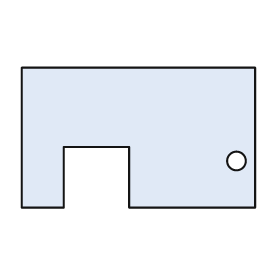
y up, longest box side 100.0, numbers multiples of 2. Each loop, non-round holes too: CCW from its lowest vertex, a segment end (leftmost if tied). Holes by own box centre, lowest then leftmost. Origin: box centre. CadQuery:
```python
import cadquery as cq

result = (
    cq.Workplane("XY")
    .moveTo(-50.0, -30.0)
    .lineTo(-32.0, -30.0)
    .lineTo(-32.0, -4.0)
    .lineTo(-4.0, -4.0)
    .lineTo(-4.0, -30.0)
    .lineTo(50.0, -30.0)
    .lineTo(50.0, 30.0)
    .lineTo(-50.0, 30.0)
    .close()
    .moveTo(42.0, -10.0)
    .circle(4.0)
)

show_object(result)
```